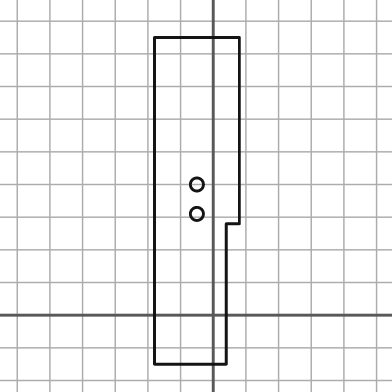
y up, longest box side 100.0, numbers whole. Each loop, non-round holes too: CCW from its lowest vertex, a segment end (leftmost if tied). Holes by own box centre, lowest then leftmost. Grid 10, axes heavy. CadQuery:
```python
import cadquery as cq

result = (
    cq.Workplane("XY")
    .moveTo(-18.0, -15.0)
    .lineTo(4.0, -15.0)
    .lineTo(4.0, 28.0)
    .lineTo(8.0, 28.0)
    .lineTo(8.0, 85.0)
    .lineTo(-18.0, 85.0)
    .close()
    .moveTo(-5.0, 31.0)
    .circle(2.0)
    .moveTo(-5.0, 40.0)
    .circle(2.0)
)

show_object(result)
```